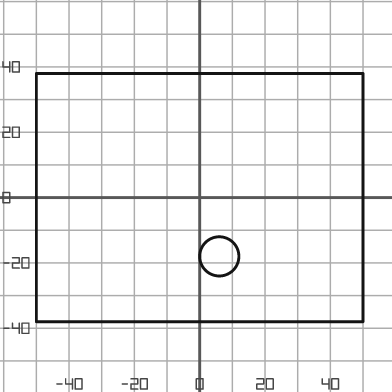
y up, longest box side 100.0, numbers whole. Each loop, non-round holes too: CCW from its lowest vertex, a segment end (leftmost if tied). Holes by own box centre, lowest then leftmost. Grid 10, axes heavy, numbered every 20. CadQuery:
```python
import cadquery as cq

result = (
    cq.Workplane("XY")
    .moveTo(-50.0, -38.0)
    .lineTo(50.0, -38.0)
    .lineTo(50.0, 38.0)
    .lineTo(-50.0, 38.0)
    .close()
    .moveTo(6.0, -18.0)
    .circle(6.0)
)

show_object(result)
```